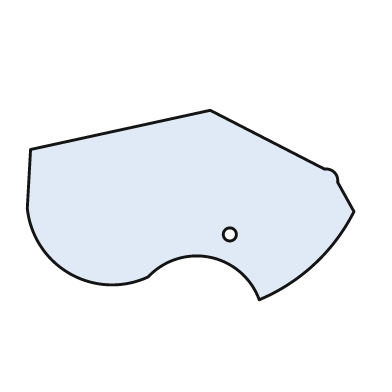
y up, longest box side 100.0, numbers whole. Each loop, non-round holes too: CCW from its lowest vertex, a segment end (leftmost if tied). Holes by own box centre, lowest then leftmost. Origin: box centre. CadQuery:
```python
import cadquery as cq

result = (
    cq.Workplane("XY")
    .moveTo(21.0, -29.0)
    .threePointArc((38.0, -18.0), (50.0, -2.0))
    .lineTo(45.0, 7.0)
    .threePointArc((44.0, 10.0), (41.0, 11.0))
    .lineTo(6.0, 29.0)
    .lineTo(-49.0, 17.0)
    .lineTo(-50.0, -1.0)
    .threePointArc((-37.0, -21.0), (-13.0, -22.0))
    .threePointArc((6.0, -16.0), (21.0, -29.0))
    .close()
    .moveTo(12.0, -9.0)
    .circle(2.0)
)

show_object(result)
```